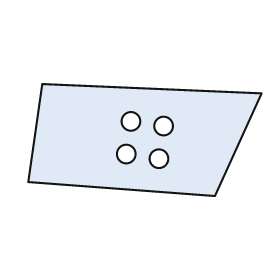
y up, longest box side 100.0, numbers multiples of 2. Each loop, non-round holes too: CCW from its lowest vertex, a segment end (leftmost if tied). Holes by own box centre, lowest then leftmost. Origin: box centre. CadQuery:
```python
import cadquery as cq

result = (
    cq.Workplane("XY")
    .moveTo(30.0, -24.0)
    .lineTo(50.0, 20.0)
    .lineTo(-44.0, 24.0)
    .lineTo(-50.0, -18.0)
    .close()
    .moveTo(6.0, -8.0)
    .circle(4.0)
    .moveTo(-8.0, -6.0)
    .circle(4.0)
    .moveTo(8.0, 6.0)
    .circle(4.0)
    .moveTo(-6.0, 8.0)
    .circle(4.0)
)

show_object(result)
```